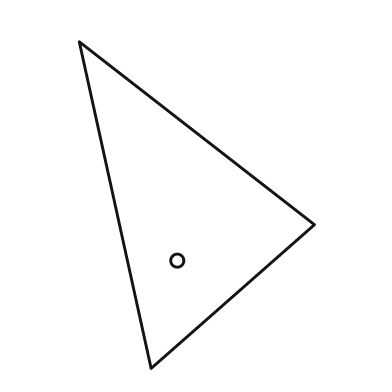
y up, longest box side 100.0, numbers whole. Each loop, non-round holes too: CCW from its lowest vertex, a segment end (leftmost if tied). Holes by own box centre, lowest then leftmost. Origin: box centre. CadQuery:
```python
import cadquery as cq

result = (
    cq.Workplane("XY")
    .moveTo(-14.0, -50.0)
    .lineTo(36.0, -6.0)
    .lineTo(-36.0, 50.0)
    .close()
    .moveTo(-6.0, -17.0)
    .circle(2.0)
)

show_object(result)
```